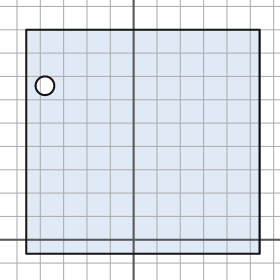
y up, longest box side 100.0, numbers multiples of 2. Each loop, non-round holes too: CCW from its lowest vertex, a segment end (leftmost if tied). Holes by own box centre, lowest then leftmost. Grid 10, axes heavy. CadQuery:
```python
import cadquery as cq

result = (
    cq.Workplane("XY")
    .moveTo(-46.0, -6.0)
    .lineTo(54.0, -6.0)
    .lineTo(54.0, 90.0)
    .lineTo(-46.0, 90.0)
    .close()
    .moveTo(-38.0, 66.0)
    .circle(4.0)
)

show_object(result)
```